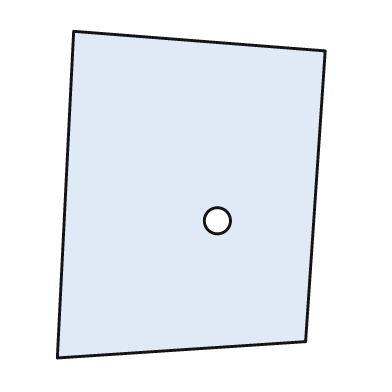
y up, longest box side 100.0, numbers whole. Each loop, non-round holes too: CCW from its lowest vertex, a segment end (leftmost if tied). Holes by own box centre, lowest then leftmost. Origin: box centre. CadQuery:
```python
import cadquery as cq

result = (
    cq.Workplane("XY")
    .moveTo(-41.0, -50.0)
    .lineTo(35.0, -45.0)
    .lineTo(41.0, 44.0)
    .lineTo(-36.0, 50.0)
    .close()
    .moveTo(8.0, -8.0)
    .circle(4.0)
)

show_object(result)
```